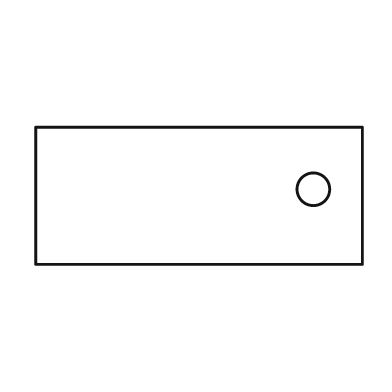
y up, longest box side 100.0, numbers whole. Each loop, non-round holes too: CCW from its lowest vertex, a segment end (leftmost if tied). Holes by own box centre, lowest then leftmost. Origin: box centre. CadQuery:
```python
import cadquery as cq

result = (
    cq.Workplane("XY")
    .moveTo(-50.0, -21.0)
    .lineTo(50.0, -21.0)
    .lineTo(50.0, 21.0)
    .lineTo(-50.0, 21.0)
    .close()
    .moveTo(35.0, 2.0)
    .circle(5.0)
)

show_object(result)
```